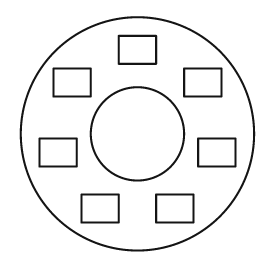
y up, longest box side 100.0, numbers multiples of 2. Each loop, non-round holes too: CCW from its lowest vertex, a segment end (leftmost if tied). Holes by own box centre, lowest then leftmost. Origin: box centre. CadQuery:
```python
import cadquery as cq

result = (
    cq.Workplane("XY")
    .moveTo(0.0, 0.0)
    .circle(50.0)
    .moveTo(-24.0, -38.0)
    .lineTo(-8.0, -38.0)
    .lineTo(-8.0, -26.0)
    .lineTo(-24.0, -26.0)
    .close()
    .moveTo(8.0, -38.0)
    .lineTo(24.0, -38.0)
    .lineTo(24.0, -26.0)
    .lineTo(8.0, -26.0)
    .close()
    .moveTo(-42.0, -14.0)
    .lineTo(-26.0, -14.0)
    .lineTo(-26.0, -2.0)
    .lineTo(-42.0, -2.0)
    .close()
    .moveTo(26.0, -14.0)
    .lineTo(42.0, -14.0)
    .lineTo(42.0, -2.0)
    .lineTo(26.0, -2.0)
    .close()
    .moveTo(0.0, 0.0)
    .circle(20.0)
    .moveTo(-36.0, 16.0)
    .lineTo(-20.0, 16.0)
    .lineTo(-20.0, 28.0)
    .lineTo(-36.0, 28.0)
    .close()
    .moveTo(20.0, 16.0)
    .lineTo(36.0, 16.0)
    .lineTo(36.0, 28.0)
    .lineTo(20.0, 28.0)
    .close()
    .moveTo(-8.0, 30.0)
    .lineTo(8.0, 30.0)
    .lineTo(8.0, 42.0)
    .lineTo(-8.0, 42.0)
    .close()
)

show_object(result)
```